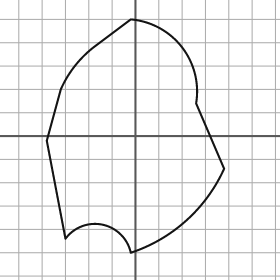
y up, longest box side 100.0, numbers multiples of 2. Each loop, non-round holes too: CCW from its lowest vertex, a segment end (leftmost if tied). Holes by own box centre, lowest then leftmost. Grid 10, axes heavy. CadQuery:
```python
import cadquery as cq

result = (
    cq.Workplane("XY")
    .moveTo(-2.0, -50.0)
    .threePointArc((22.0, -36.0), (38.0, -14.0))
    .lineTo(26.0, 14.0)
    .threePointArc((20.0, 38.0), (-2.0, 50.0))
    .lineTo(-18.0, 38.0)
    .threePointArc((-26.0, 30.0), (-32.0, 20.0))
    .lineTo(-38.0, -2.0)
    .lineTo(-30.0, -44.0)
    .threePointArc((-14.0, -38.0), (-2.0, -50.0))
    .close()
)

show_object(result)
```